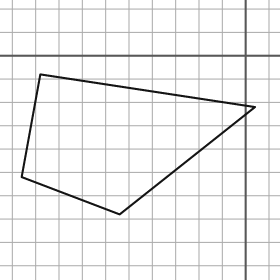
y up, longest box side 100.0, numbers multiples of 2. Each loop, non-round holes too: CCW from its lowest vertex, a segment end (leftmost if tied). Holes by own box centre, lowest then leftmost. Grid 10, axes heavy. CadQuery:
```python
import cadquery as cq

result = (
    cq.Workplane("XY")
    .moveTo(-54.0, -68.0)
    .lineTo(4.0, -22.0)
    .lineTo(-88.0, -8.0)
    .lineTo(-96.0, -52.0)
    .close()
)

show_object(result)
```